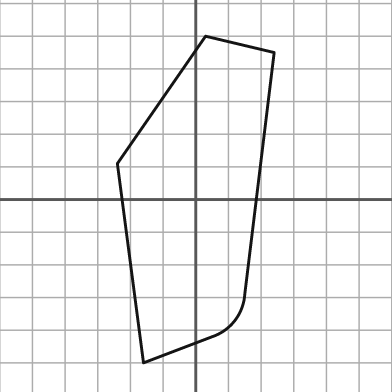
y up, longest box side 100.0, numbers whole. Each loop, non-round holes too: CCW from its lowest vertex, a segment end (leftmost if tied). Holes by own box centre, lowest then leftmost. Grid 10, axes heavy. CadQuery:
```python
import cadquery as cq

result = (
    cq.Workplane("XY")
    .moveTo(-16.0, -50.0)
    .lineTo(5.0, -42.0)
    .threePointArc((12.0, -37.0), (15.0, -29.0))
    .lineTo(24.0, 45.0)
    .lineTo(3.0, 50.0)
    .lineTo(-24.0, 11.0)
    .close()
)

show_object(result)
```